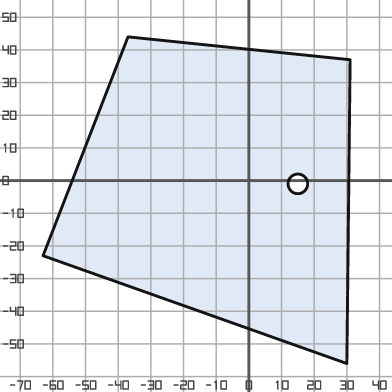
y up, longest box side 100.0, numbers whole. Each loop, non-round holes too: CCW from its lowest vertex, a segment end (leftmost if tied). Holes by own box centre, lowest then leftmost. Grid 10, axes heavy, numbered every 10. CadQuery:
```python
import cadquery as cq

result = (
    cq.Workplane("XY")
    .moveTo(30.0, -56.0)
    .lineTo(31.0, 37.0)
    .lineTo(-37.0, 44.0)
    .lineTo(-63.0, -23.0)
    .close()
    .moveTo(15.0, -1.0)
    .circle(3.0)
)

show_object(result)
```